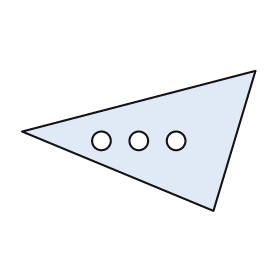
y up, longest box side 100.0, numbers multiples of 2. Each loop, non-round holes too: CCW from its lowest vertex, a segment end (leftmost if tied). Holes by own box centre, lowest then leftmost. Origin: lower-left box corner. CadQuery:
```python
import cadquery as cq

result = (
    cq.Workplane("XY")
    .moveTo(82.0, 0.0)
    .lineTo(100.0, 60.0)
    .lineTo(0.0, 34.0)
    .close()
    .moveTo(34.0, 30.0)
    .circle(4.0)
    .moveTo(50.0, 30.0)
    .circle(4.0)
    .moveTo(66.0, 30.0)
    .circle(4.0)
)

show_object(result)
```